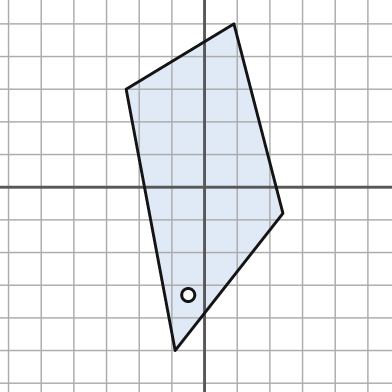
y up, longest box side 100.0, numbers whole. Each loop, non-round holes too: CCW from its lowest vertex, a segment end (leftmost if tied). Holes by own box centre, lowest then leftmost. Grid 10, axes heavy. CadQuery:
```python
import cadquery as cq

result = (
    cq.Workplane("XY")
    .moveTo(-9.0, -50.0)
    .lineTo(24.0, -8.0)
    .lineTo(9.0, 50.0)
    .lineTo(-24.0, 30.0)
    .close()
    .moveTo(-5.0, -33.0)
    .circle(2.0)
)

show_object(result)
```